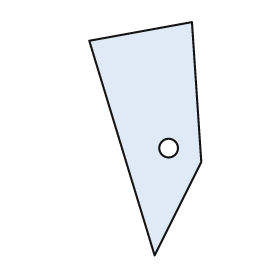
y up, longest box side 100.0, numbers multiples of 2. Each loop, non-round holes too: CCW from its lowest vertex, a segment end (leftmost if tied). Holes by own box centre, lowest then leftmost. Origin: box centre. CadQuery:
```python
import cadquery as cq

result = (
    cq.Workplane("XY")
    .moveTo(4.0, -50.0)
    .lineTo(24.0, -10.0)
    .lineTo(20.0, 50.0)
    .lineTo(-24.0, 42.0)
    .close()
    .moveTo(10.0, -4.0)
    .circle(4.0)
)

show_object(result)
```